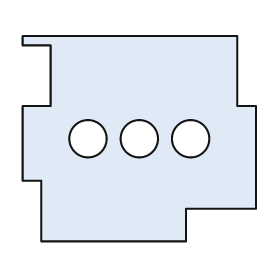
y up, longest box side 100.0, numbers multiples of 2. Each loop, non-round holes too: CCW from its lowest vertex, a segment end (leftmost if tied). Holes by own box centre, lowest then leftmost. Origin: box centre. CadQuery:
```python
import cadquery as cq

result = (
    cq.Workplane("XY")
    .moveTo(-42.0, -44.0)
    .lineTo(20.0, -44.0)
    .lineTo(20.0, -30.0)
    .lineTo(50.0, -30.0)
    .lineTo(50.0, 14.0)
    .lineTo(42.0, 14.0)
    .lineTo(42.0, 44.0)
    .lineTo(-50.0, 44.0)
    .lineTo(-50.0, 40.0)
    .lineTo(-38.0, 40.0)
    .lineTo(-38.0, 14.0)
    .lineTo(-50.0, 14.0)
    .lineTo(-50.0, -18.0)
    .lineTo(-42.0, -18.0)
    .close()
    .moveTo(-22.0, 0.0)
    .circle(8.0)
    .moveTo(0.0, 0.0)
    .circle(8.0)
    .moveTo(22.0, 0.0)
    .circle(8.0)
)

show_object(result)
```